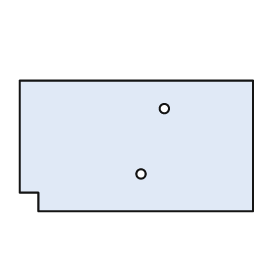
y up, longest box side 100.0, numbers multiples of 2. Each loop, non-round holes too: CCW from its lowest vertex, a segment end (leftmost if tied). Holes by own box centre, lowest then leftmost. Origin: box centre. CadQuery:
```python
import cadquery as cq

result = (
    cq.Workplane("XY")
    .moveTo(-42.0, -28.0)
    .lineTo(50.0, -28.0)
    .lineTo(50.0, 28.0)
    .lineTo(-50.0, 28.0)
    .lineTo(-50.0, -20.0)
    .lineTo(-42.0, -20.0)
    .close()
    .moveTo(2.0, -12.0)
    .circle(2.0)
    .moveTo(12.0, 16.0)
    .circle(2.0)
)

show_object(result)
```